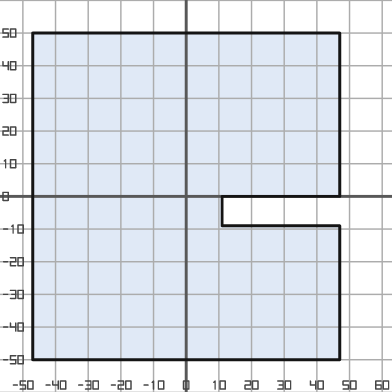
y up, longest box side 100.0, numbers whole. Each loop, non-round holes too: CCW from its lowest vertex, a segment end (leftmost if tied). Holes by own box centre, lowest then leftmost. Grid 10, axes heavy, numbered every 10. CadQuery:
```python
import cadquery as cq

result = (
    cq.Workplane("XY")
    .moveTo(-47.0, -50.0)
    .lineTo(47.0, -50.0)
    .lineTo(47.0, -9.0)
    .lineTo(11.0, -9.0)
    .lineTo(11.0, 0.0)
    .lineTo(47.0, 0.0)
    .lineTo(47.0, 50.0)
    .lineTo(-47.0, 50.0)
    .close()
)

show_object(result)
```